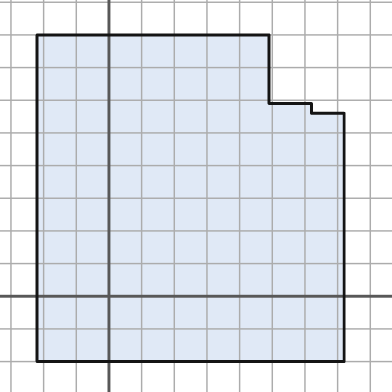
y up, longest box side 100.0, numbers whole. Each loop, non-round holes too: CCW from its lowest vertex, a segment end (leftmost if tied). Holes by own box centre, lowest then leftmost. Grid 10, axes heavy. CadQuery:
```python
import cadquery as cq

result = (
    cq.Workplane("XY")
    .moveTo(-22.0, -20.0)
    .lineTo(72.0, -20.0)
    .lineTo(72.0, 56.0)
    .lineTo(62.0, 56.0)
    .lineTo(62.0, 59.0)
    .lineTo(49.0, 59.0)
    .lineTo(49.0, 80.0)
    .lineTo(-22.0, 80.0)
    .close()
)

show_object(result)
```